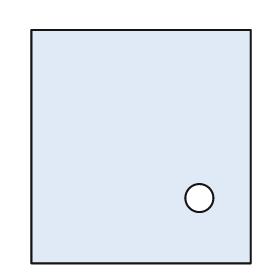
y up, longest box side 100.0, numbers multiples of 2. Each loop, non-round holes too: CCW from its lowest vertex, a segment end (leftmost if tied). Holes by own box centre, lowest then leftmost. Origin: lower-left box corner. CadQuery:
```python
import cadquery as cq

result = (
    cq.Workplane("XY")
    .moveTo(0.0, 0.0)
    .lineTo(94.0, 0.0)
    .lineTo(94.0, 100.0)
    .lineTo(0.0, 100.0)
    .close()
    .moveTo(72.0, 28.0)
    .circle(6.0)
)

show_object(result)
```